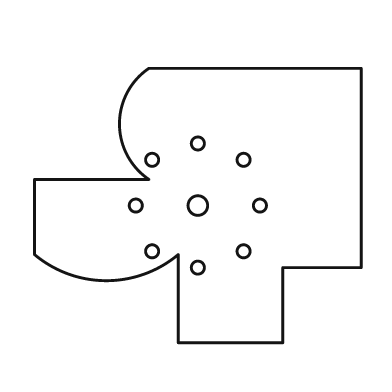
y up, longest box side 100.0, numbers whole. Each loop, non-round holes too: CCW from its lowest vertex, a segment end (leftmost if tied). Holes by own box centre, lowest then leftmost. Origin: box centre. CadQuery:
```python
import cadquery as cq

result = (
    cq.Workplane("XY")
    .moveTo(-6.0, -42.0)
    .lineTo(26.0, -42.0)
    .lineTo(26.0, -19.0)
    .lineTo(50.0, -19.0)
    .lineTo(50.0, 42.0)
    .lineTo(-15.0, 42.0)
    .threePointArc((-24.0, 25.0), (-15.0, 8.0))
    .lineTo(-50.0, 8.0)
    .lineTo(-50.0, -15.0)
    .threePointArc((-28.0, -23.0), (-6.0, -15.0))
    .close()
    .moveTo(0.0, -19.0)
    .circle(2.0)
    .moveTo(-14.0, -14.0)
    .circle(2.0)
    .moveTo(14.0, -14.0)
    .circle(2.0)
    .moveTo(-19.0, 0.0)
    .circle(2.0)
    .moveTo(0.0, 0.0)
    .circle(3.0)
    .moveTo(19.0, 0.0)
    .circle(2.0)
    .moveTo(-14.0, 14.0)
    .circle(2.0)
    .moveTo(14.0, 14.0)
    .circle(2.0)
    .moveTo(0.0, 19.0)
    .circle(2.0)
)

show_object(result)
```